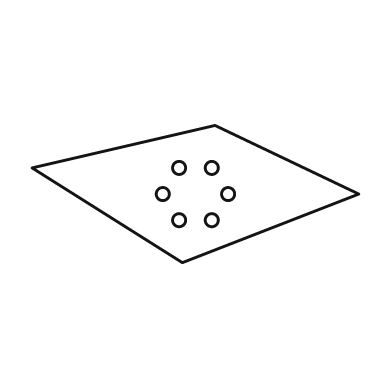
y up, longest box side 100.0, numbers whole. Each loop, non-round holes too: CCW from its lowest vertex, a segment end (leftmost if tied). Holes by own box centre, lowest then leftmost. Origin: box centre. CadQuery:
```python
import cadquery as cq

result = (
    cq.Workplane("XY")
    .moveTo(-4.0, -21.0)
    .lineTo(50.0, 0.0)
    .lineTo(6.0, 21.0)
    .lineTo(-50.0, 8.0)
    .close()
    .moveTo(-5.0, -8.0)
    .circle(2.0)
    .moveTo(5.0, -8.0)
    .circle(2.0)
    .moveTo(-10.0, 0.0)
    .circle(2.0)
    .moveTo(10.0, 0.0)
    .circle(2.0)
    .moveTo(-5.0, 8.0)
    .circle(2.0)
    .moveTo(5.0, 8.0)
    .circle(2.0)
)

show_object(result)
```